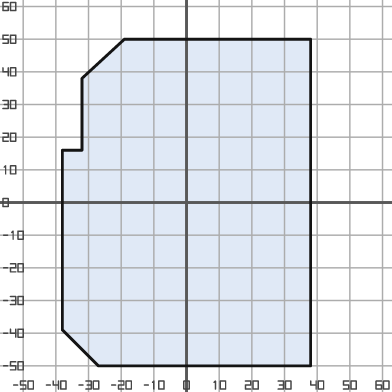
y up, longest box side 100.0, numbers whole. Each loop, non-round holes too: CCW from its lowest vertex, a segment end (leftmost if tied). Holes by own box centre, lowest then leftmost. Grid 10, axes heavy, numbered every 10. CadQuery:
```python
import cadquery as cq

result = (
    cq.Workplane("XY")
    .moveTo(-27.0, -50.0)
    .lineTo(38.0, -50.0)
    .lineTo(38.0, 50.0)
    .lineTo(-19.0, 50.0)
    .lineTo(-32.0, 38.0)
    .lineTo(-32.0, 16.0)
    .lineTo(-38.0, 16.0)
    .lineTo(-38.0, -39.0)
    .close()
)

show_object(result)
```